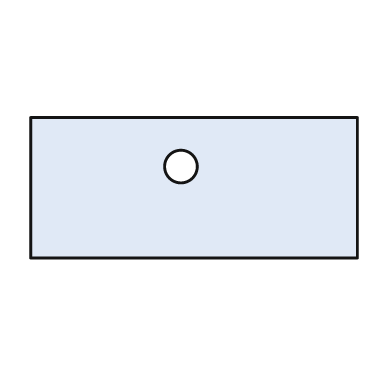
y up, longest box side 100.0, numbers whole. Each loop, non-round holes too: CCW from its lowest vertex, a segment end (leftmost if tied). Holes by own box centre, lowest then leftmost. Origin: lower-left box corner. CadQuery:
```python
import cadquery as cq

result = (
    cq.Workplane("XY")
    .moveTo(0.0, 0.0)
    .lineTo(100.0, 0.0)
    .lineTo(100.0, 43.0)
    .lineTo(0.0, 43.0)
    .close()
    .moveTo(46.0, 28.0)
    .circle(5.0)
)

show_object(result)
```